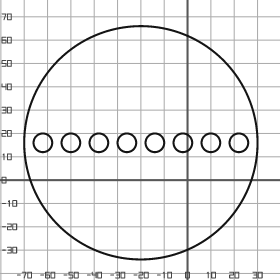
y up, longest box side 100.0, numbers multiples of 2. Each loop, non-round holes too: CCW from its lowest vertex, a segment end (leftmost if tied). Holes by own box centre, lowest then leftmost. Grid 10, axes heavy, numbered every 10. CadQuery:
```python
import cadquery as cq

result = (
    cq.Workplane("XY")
    .moveTo(-20.0, 16.0)
    .circle(50.0)
    .moveTo(-62.0, 16.0)
    .circle(4.0)
    .moveTo(-50.0, 16.0)
    .circle(4.0)
    .moveTo(-38.0, 16.0)
    .circle(4.0)
    .moveTo(-26.0, 16.0)
    .circle(4.0)
    .moveTo(-14.0, 16.0)
    .circle(4.0)
    .moveTo(-2.0, 16.0)
    .circle(4.0)
    .moveTo(10.0, 16.0)
    .circle(4.0)
    .moveTo(22.0, 16.0)
    .circle(4.0)
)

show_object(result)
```